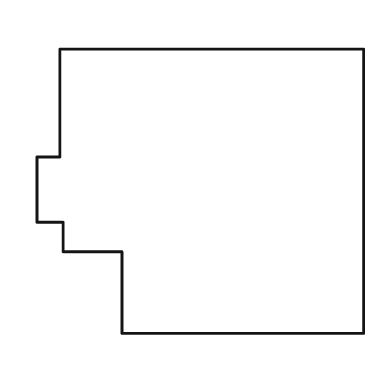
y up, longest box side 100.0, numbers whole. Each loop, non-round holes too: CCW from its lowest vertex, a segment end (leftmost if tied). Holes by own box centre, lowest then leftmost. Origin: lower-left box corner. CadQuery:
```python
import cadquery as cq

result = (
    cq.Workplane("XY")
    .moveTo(26.0, 0.0)
    .lineTo(100.0, 0.0)
    .lineTo(100.0, 87.0)
    .lineTo(7.0, 87.0)
    .lineTo(7.0, 54.0)
    .lineTo(0.0, 54.0)
    .lineTo(0.0, 34.0)
    .lineTo(8.0, 34.0)
    .lineTo(8.0, 25.0)
    .lineTo(26.0, 25.0)
    .close()
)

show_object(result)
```